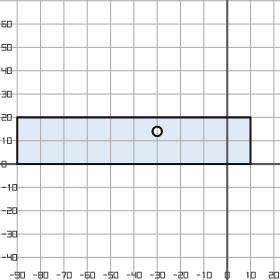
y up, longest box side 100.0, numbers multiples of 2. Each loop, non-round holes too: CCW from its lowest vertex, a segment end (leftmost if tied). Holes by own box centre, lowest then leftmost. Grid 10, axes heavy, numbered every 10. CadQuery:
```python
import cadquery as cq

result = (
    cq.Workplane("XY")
    .moveTo(-90.0, 0.0)
    .lineTo(10.0, 0.0)
    .lineTo(10.0, 20.0)
    .lineTo(-90.0, 20.0)
    .close()
    .moveTo(-30.0, 14.0)
    .circle(2.0)
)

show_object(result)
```